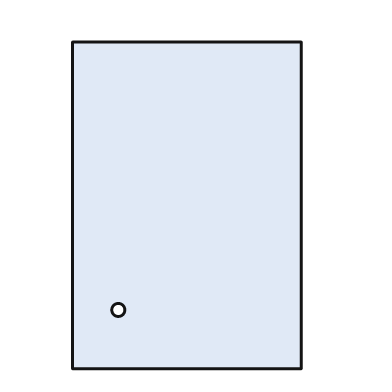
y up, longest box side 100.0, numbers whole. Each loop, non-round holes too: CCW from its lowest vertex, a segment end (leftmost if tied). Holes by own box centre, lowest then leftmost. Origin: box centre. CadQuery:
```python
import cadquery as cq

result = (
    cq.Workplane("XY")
    .moveTo(-35.0, -50.0)
    .lineTo(35.0, -50.0)
    .lineTo(35.0, 50.0)
    .lineTo(-35.0, 50.0)
    .close()
    .moveTo(-21.0, -32.0)
    .circle(2.0)
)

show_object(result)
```